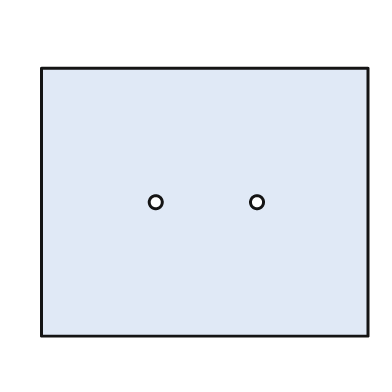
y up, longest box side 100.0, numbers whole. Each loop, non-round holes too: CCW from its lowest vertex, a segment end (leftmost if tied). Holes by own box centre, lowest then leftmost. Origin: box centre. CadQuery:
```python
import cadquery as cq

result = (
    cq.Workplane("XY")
    .moveTo(-50.0, -41.0)
    .lineTo(50.0, -41.0)
    .lineTo(50.0, 41.0)
    .lineTo(-50.0, 41.0)
    .close()
    .moveTo(-15.0, 0.0)
    .circle(2.0)
    .moveTo(16.0, 0.0)
    .circle(2.0)
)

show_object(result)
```